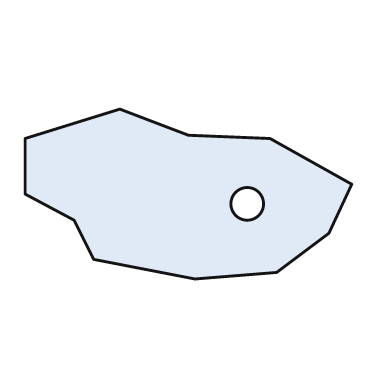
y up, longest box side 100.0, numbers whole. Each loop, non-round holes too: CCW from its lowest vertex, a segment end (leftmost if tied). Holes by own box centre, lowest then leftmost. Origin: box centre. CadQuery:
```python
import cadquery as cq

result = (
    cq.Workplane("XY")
    .moveTo(2.0, -26.0)
    .lineTo(27.0, -24.0)
    .lineTo(43.0, -12.0)
    .lineTo(50.0, 3.0)
    .lineTo(25.0, 17.0)
    .lineTo(0.0, 18.0)
    .lineTo(-21.0, 26.0)
    .lineTo(-50.0, 17.0)
    .lineTo(-50.0, 0.0)
    .lineTo(-35.0, -8.0)
    .lineTo(-29.0, -20.0)
    .close()
    .moveTo(18.0, -3.0)
    .circle(5.0)
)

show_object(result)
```